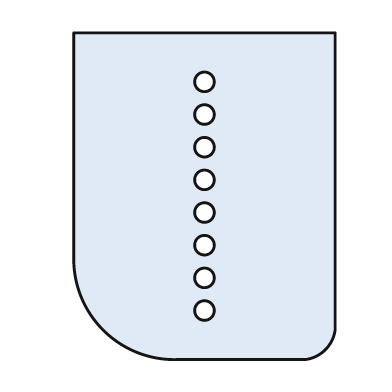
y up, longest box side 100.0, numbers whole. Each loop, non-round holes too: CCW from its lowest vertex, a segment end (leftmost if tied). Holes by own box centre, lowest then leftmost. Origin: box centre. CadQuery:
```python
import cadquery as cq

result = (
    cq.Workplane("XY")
    .moveTo(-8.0, -50.0)
    .lineTo(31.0, -50.0)
    .threePointArc((37.0, -47.0), (40.0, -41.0))
    .lineTo(40.0, 50.0)
    .lineTo(-40.0, 50.0)
    .lineTo(-40.0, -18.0)
    .threePointArc((-31.0, -41.0), (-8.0, -50.0))
    .close()
    .moveTo(0.0, -35.0)
    .circle(3.0)
    .moveTo(0.0, -25.0)
    .circle(3.0)
    .moveTo(0.0, -15.0)
    .circle(3.0)
    .moveTo(0.0, -5.0)
    .circle(3.0)
    .moveTo(0.0, 5.0)
    .circle(3.0)
    .moveTo(0.0, 15.0)
    .circle(3.0)
    .moveTo(0.0, 25.0)
    .circle(3.0)
    .moveTo(0.0, 35.0)
    .circle(3.0)
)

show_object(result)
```